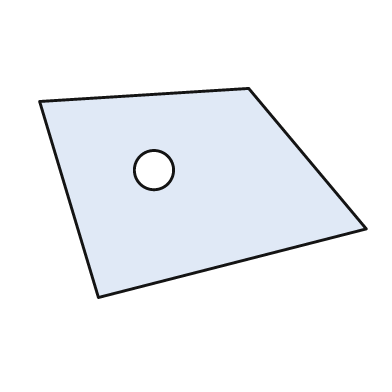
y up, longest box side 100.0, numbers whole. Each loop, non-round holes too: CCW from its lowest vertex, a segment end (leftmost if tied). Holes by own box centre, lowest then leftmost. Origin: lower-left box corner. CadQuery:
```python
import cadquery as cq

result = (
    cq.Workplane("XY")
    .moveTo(18.0, 0.0)
    .lineTo(100.0, 21.0)
    .lineTo(64.0, 64.0)
    .lineTo(0.0, 60.0)
    .close()
    .moveTo(35.0, 39.0)
    .circle(6.0)
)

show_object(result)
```